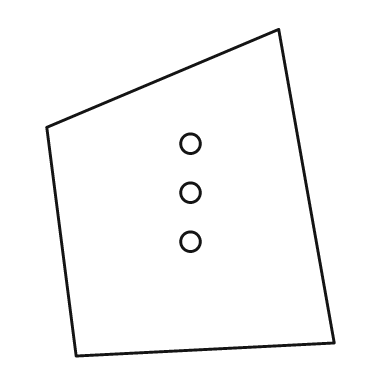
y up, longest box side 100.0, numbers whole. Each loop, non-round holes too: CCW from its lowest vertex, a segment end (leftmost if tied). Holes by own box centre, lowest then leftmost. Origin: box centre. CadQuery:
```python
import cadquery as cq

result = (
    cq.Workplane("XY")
    .moveTo(-35.0, -50.0)
    .lineTo(44.0, -46.0)
    .lineTo(27.0, 50.0)
    .lineTo(-44.0, 20.0)
    .close()
    .moveTo(0.0, -15.0)
    .circle(3.0)
    .moveTo(0.0, 0.0)
    .circle(3.0)
    .moveTo(0.0, 15.0)
    .circle(3.0)
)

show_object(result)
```